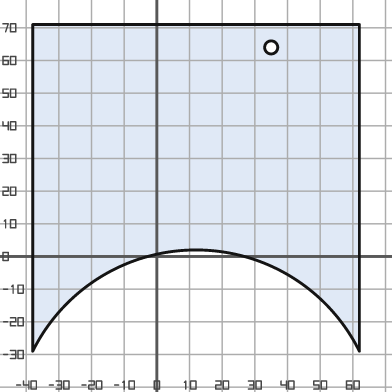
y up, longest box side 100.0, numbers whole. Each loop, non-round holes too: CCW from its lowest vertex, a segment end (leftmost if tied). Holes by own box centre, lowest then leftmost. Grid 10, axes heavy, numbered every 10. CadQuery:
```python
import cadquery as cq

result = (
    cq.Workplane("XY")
    .moveTo(-38.0, -29.0)
    .threePointArc((12.0, 2.0), (62.0, -29.0))
    .lineTo(62.0, 71.0)
    .lineTo(-38.0, 71.0)
    .close()
    .moveTo(35.0, 64.0)
    .circle(2.0)
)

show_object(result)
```